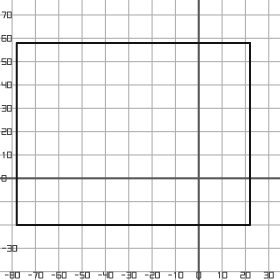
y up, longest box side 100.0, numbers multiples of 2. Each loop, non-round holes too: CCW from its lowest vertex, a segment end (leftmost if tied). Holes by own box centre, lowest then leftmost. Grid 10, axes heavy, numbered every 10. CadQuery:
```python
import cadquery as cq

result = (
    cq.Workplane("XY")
    .moveTo(-78.0, -20.0)
    .lineTo(22.0, -20.0)
    .lineTo(22.0, 58.0)
    .lineTo(-78.0, 58.0)
    .close()
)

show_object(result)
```